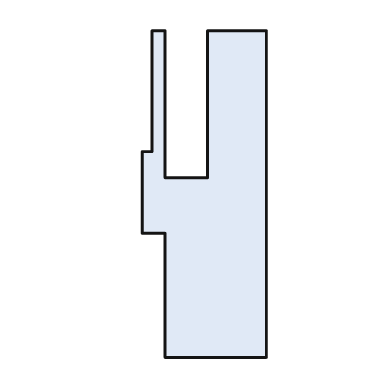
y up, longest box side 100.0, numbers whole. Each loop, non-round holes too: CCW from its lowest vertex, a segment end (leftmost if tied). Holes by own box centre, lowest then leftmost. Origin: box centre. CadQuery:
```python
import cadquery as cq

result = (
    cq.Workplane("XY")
    .moveTo(-12.0, -50.0)
    .lineTo(19.0, -50.0)
    .lineTo(19.0, 50.0)
    .lineTo(1.0, 50.0)
    .lineTo(1.0, 5.0)
    .lineTo(-12.0, 5.0)
    .lineTo(-12.0, 50.0)
    .lineTo(-16.0, 50.0)
    .lineTo(-16.0, 13.0)
    .lineTo(-19.0, 13.0)
    .lineTo(-19.0, -12.0)
    .lineTo(-12.0, -12.0)
    .close()
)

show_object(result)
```